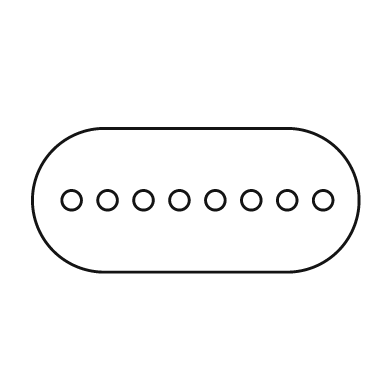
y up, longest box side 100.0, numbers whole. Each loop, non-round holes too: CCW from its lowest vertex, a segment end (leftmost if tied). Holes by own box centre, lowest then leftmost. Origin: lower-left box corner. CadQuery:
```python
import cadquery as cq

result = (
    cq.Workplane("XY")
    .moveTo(22.0, 0.0)
    .lineTo(78.0, 0.0)
    .threePointArc((100.0, 22.0), (78.0, 44.0))
    .lineTo(22.0, 44.0)
    .threePointArc((0.0, 22.0), (22.0, 0.0))
    .close()
    .moveTo(12.0, 22.0)
    .circle(3.0)
    .moveTo(23.0, 22.0)
    .circle(3.0)
    .moveTo(34.0, 22.0)
    .circle(3.0)
    .moveTo(45.0, 22.0)
    .circle(3.0)
    .moveTo(56.0, 22.0)
    .circle(3.0)
    .moveTo(67.0, 22.0)
    .circle(3.0)
    .moveTo(78.0, 22.0)
    .circle(3.0)
    .moveTo(89.0, 22.0)
    .circle(3.0)
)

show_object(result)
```